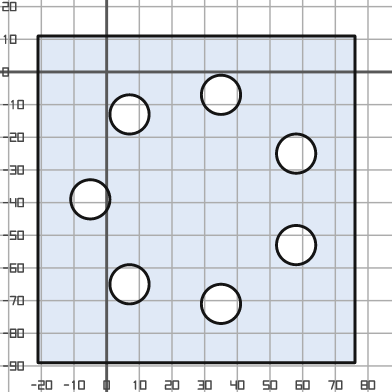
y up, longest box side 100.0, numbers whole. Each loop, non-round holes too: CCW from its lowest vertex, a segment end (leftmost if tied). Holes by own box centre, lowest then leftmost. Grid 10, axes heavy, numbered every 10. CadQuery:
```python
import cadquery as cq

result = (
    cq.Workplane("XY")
    .moveTo(-21.0, -89.0)
    .lineTo(76.0, -89.0)
    .lineTo(76.0, 11.0)
    .lineTo(-21.0, 11.0)
    .close()
    .moveTo(35.0, -71.0)
    .circle(6.0)
    .moveTo(7.0, -65.0)
    .circle(6.0)
    .moveTo(58.0, -53.0)
    .circle(6.0)
    .moveTo(-5.0, -39.0)
    .circle(6.0)
    .moveTo(58.0, -25.0)
    .circle(6.0)
    .moveTo(7.0, -13.0)
    .circle(6.0)
    .moveTo(35.0, -7.0)
    .circle(6.0)
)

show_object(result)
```